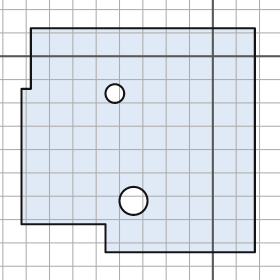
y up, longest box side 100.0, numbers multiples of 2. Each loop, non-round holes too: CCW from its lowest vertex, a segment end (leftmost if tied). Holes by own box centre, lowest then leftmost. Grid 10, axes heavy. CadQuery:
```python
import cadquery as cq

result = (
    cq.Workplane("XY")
    .moveTo(-46.0, -84.0)
    .lineTo(18.0, -84.0)
    .lineTo(18.0, 12.0)
    .lineTo(-78.0, 12.0)
    .lineTo(-78.0, -14.0)
    .lineTo(-82.0, -14.0)
    .lineTo(-82.0, -72.0)
    .lineTo(-46.0, -72.0)
    .close()
    .moveTo(-34.0, -62.0)
    .circle(6.0)
    .moveTo(-42.0, -16.0)
    .circle(4.0)
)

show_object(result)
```